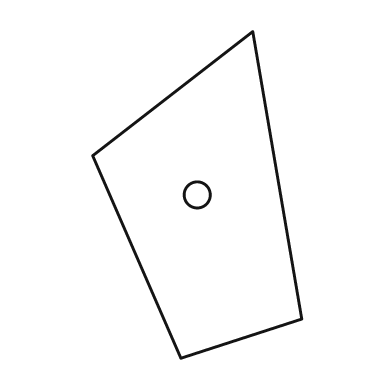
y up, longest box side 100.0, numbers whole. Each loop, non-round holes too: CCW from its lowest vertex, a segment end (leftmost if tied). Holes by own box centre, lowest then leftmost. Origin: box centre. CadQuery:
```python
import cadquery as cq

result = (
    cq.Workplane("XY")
    .moveTo(-5.0, -50.0)
    .lineTo(32.0, -38.0)
    .lineTo(17.0, 50.0)
    .lineTo(-32.0, 12.0)
    .close()
    .moveTo(0.0, 0.0)
    .circle(4.0)
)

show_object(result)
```